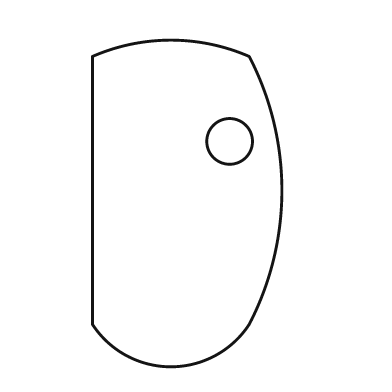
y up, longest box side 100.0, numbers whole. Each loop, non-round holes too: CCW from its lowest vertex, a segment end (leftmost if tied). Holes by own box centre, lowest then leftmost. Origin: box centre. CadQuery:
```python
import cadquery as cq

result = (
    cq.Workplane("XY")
    .moveTo(-29.0, -37.0)
    .threePointArc((-5.0, -50.0), (19.0, -37.0))
    .threePointArc((29.0, 4.0), (19.0, 45.0))
    .threePointArc((-5.0, 50.0), (-29.0, 45.0))
    .close()
    .moveTo(13.0, 19.0)
    .circle(7.0)
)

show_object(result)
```